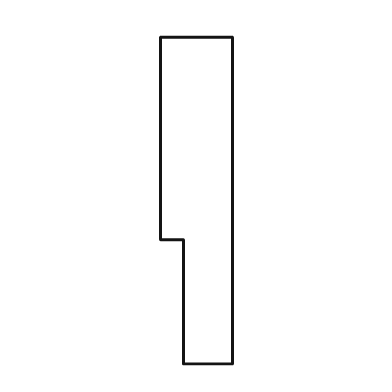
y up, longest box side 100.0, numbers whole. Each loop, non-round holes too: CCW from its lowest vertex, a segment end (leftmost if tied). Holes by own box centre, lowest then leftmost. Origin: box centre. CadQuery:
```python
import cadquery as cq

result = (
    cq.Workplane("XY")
    .moveTo(-4.0, -50.0)
    .lineTo(11.0, -50.0)
    .lineTo(11.0, 50.0)
    .lineTo(-11.0, 50.0)
    .lineTo(-11.0, -12.0)
    .lineTo(-4.0, -12.0)
    .close()
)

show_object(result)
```